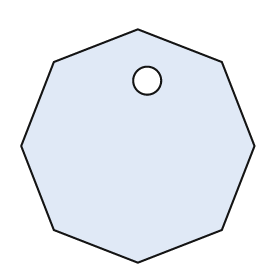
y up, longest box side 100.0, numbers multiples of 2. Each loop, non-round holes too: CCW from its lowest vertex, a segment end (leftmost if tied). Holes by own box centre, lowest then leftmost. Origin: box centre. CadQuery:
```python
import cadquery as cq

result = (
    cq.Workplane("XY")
    .moveTo(0.0, -50.0)
    .lineTo(36.0, -36.0)
    .lineTo(50.0, 0.0)
    .lineTo(36.0, 36.0)
    .lineTo(0.0, 50.0)
    .lineTo(-36.0, 36.0)
    .lineTo(-50.0, 0.0)
    .lineTo(-36.0, -36.0)
    .close()
    .moveTo(4.0, 28.0)
    .circle(6.0)
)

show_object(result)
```